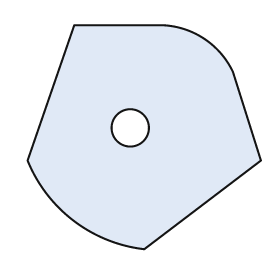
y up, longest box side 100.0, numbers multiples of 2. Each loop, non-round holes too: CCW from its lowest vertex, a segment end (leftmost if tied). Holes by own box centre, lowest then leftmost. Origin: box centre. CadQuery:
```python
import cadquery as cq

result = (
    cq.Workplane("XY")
    .moveTo(0.0, -48.0)
    .lineTo(50.0, -10.0)
    .lineTo(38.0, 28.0)
    .threePointArc((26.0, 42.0), (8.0, 48.0))
    .lineTo(-30.0, 48.0)
    .lineTo(-50.0, -10.0)
    .threePointArc((-30.0, -36.0), (0.0, -48.0))
    .close()
    .moveTo(-6.0, 4.0)
    .circle(8.0)
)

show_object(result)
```